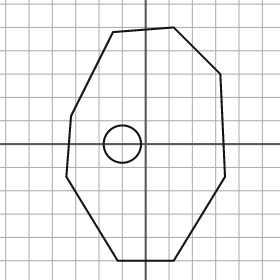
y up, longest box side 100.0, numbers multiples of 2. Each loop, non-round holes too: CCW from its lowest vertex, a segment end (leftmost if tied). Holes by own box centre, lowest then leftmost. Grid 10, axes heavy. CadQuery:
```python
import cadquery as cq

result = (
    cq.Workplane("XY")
    .moveTo(-12.0, -50.0)
    .lineTo(12.0, -50.0)
    .lineTo(34.0, -14.0)
    .lineTo(32.0, 30.0)
    .lineTo(12.0, 50.0)
    .lineTo(-14.0, 48.0)
    .lineTo(-32.0, 12.0)
    .lineTo(-34.0, -14.0)
    .close()
    .moveTo(-10.0, 0.0)
    .circle(8.0)
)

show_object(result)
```